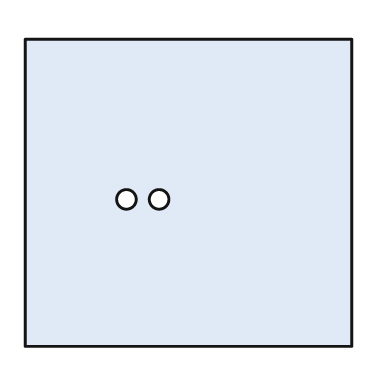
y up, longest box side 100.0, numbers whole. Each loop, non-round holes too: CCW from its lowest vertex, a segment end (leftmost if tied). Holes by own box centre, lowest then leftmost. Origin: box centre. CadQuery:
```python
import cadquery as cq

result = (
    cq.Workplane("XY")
    .moveTo(-50.0, -47.0)
    .lineTo(50.0, -47.0)
    .lineTo(50.0, 47.0)
    .lineTo(-50.0, 47.0)
    .close()
    .moveTo(-19.0, -2.0)
    .circle(3.0)
    .moveTo(-9.0, -2.0)
    .circle(3.0)
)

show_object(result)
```